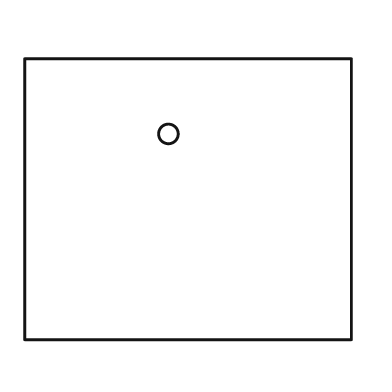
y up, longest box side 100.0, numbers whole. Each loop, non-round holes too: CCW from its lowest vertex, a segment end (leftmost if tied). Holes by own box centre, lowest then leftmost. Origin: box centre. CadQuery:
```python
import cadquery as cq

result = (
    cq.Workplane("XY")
    .moveTo(-50.0, -43.0)
    .lineTo(50.0, -43.0)
    .lineTo(50.0, 43.0)
    .lineTo(-50.0, 43.0)
    .close()
    .moveTo(-6.0, 20.0)
    .circle(3.0)
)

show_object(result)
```